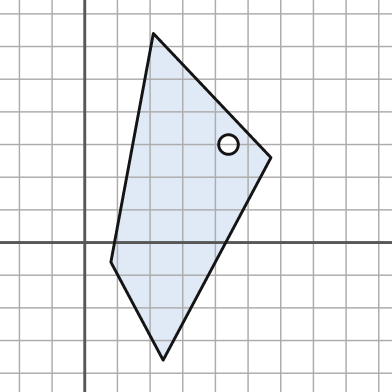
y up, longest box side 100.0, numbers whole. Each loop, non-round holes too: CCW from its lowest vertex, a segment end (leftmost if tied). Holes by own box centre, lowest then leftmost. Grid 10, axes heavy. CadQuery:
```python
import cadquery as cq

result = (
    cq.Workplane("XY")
    .moveTo(24.0, -36.0)
    .lineTo(57.0, 26.0)
    .lineTo(21.0, 64.0)
    .lineTo(8.0, -6.0)
    .close()
    .moveTo(44.0, 30.0)
    .circle(3.0)
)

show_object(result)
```